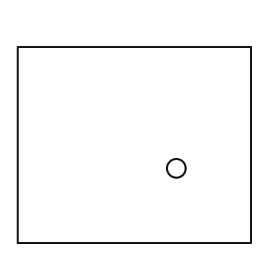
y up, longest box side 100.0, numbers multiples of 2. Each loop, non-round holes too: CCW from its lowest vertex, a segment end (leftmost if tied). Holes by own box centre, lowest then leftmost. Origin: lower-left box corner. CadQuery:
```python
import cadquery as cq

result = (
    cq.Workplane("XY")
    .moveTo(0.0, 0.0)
    .lineTo(100.0, 0.0)
    .lineTo(100.0, 84.0)
    .lineTo(0.0, 84.0)
    .close()
    .moveTo(68.0, 32.0)
    .circle(4.0)
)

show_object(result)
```